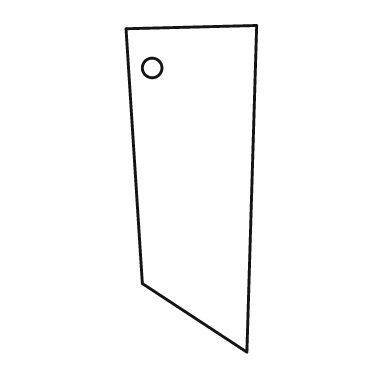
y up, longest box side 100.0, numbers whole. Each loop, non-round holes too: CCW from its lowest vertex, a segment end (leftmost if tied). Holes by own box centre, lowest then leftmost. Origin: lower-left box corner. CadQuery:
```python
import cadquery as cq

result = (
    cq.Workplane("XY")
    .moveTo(37.0, 0.0)
    .lineTo(40.0, 100.0)
    .lineTo(0.0, 99.0)
    .lineTo(5.0, 21.0)
    .close()
    .moveTo(8.0, 87.0)
    .circle(3.0)
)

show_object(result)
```